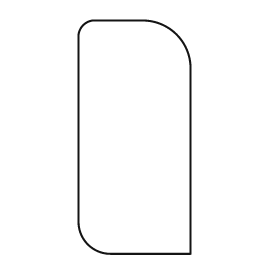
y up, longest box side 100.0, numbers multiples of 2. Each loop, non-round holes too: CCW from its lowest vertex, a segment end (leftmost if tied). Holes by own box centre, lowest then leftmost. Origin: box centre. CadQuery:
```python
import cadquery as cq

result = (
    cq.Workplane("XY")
    .moveTo(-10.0, -50.0)
    .lineTo(24.0, -50.0)
    .lineTo(24.0, 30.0)
    .threePointArc((18.0, 44.0), (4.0, 50.0))
    .lineTo(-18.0, 50.0)
    .threePointArc((-22.0, 48.0), (-24.0, 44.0))
    .lineTo(-24.0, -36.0)
    .threePointArc((-20.0, -46.0), (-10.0, -50.0))
    .close()
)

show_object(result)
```